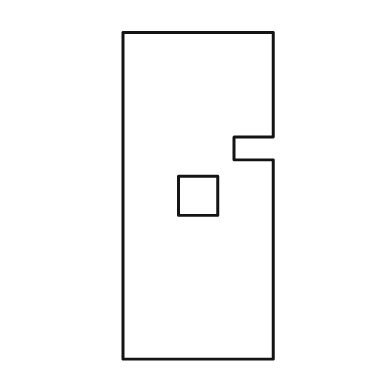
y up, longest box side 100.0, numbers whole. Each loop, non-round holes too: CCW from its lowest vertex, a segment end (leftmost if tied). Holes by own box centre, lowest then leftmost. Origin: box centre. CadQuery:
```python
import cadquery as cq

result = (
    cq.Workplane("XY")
    .moveTo(-23.0, -50.0)
    .lineTo(23.0, -50.0)
    .lineTo(23.0, 11.0)
    .lineTo(11.0, 11.0)
    .lineTo(11.0, 18.0)
    .lineTo(23.0, 18.0)
    .lineTo(23.0, 50.0)
    .lineTo(-23.0, 50.0)
    .close()
    .moveTo(-6.0, -6.0)
    .lineTo(6.0, -6.0)
    .lineTo(6.0, 6.0)
    .lineTo(-6.0, 6.0)
    .close()
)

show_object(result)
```